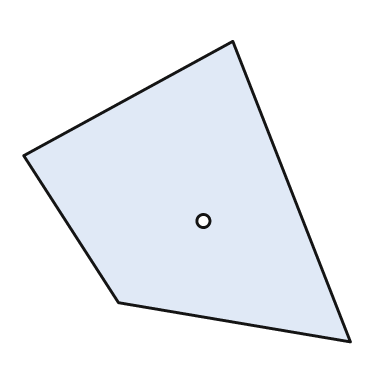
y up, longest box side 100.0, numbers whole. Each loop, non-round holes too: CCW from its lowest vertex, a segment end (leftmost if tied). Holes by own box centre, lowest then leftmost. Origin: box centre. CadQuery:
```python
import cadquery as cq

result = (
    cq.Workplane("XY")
    .moveTo(50.0, -46.0)
    .lineTo(14.0, 46.0)
    .lineTo(-50.0, 11.0)
    .lineTo(-21.0, -34.0)
    .close()
    .moveTo(5.0, -9.0)
    .circle(2.0)
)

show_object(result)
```